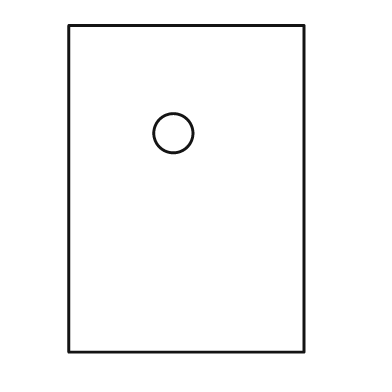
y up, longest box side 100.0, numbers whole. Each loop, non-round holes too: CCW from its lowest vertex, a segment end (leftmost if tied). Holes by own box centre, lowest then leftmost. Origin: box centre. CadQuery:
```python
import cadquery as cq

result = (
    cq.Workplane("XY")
    .moveTo(-36.0, -50.0)
    .lineTo(36.0, -50.0)
    .lineTo(36.0, 50.0)
    .lineTo(-36.0, 50.0)
    .close()
    .moveTo(-4.0, 17.0)
    .circle(6.0)
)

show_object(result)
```